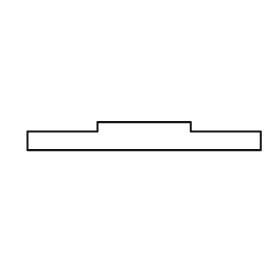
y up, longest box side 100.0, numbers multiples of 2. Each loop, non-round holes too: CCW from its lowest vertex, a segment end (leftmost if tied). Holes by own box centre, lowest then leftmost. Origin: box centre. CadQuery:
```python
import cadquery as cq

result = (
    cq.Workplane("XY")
    .moveTo(-50.0, -6.0)
    .lineTo(50.0, -6.0)
    .lineTo(50.0, 2.0)
    .lineTo(20.0, 2.0)
    .lineTo(20.0, 6.0)
    .lineTo(-20.0, 6.0)
    .lineTo(-20.0, 2.0)
    .lineTo(-50.0, 2.0)
    .close()
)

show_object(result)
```